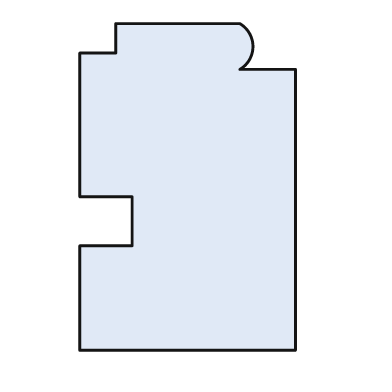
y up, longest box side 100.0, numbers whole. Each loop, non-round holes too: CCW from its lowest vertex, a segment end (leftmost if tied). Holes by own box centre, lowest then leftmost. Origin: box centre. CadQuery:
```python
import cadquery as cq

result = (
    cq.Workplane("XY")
    .moveTo(-33.0, -50.0)
    .lineTo(33.0, -50.0)
    .lineTo(33.0, 36.0)
    .lineTo(16.0, 36.0)
    .threePointArc((20.0, 43.0), (16.0, 50.0))
    .lineTo(-22.0, 50.0)
    .lineTo(-22.0, 41.0)
    .lineTo(-33.0, 41.0)
    .lineTo(-33.0, -3.0)
    .lineTo(-17.0, -3.0)
    .lineTo(-17.0, -18.0)
    .lineTo(-33.0, -18.0)
    .close()
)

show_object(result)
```